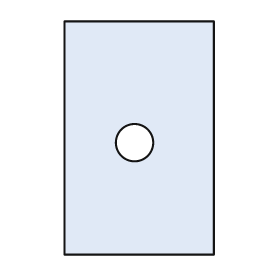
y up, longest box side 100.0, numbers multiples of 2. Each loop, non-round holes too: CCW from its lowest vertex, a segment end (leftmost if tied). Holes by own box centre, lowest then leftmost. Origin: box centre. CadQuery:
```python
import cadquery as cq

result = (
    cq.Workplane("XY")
    .moveTo(-32.0, -50.0)
    .lineTo(32.0, -50.0)
    .lineTo(32.0, 50.0)
    .lineTo(-32.0, 50.0)
    .close()
    .moveTo(-2.0, -2.0)
    .circle(8.0)
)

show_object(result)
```